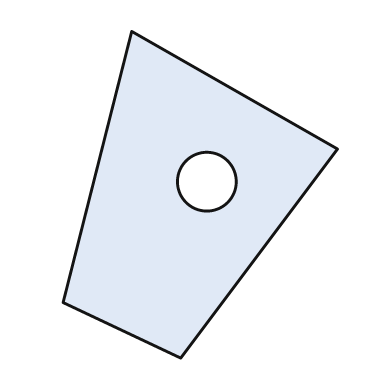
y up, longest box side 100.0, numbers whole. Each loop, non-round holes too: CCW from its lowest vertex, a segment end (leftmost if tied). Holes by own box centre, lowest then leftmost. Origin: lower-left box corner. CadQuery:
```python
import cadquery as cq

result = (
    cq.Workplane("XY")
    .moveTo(36.0, 0.0)
    .lineTo(84.0, 64.0)
    .lineTo(21.0, 100.0)
    .lineTo(0.0, 17.0)
    .close()
    .moveTo(44.0, 54.0)
    .circle(9.0)
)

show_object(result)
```